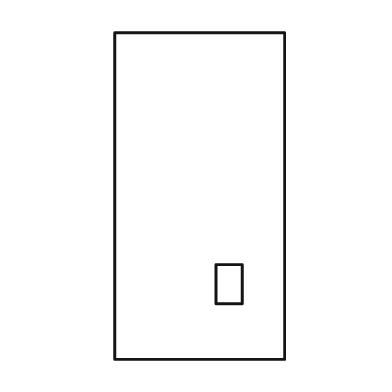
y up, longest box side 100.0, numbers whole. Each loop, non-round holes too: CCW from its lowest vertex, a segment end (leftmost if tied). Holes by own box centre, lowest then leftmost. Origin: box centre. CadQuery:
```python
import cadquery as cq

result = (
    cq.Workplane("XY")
    .moveTo(-26.0, -50.0)
    .lineTo(26.0, -50.0)
    .lineTo(26.0, 50.0)
    .lineTo(-26.0, 50.0)
    .close()
    .moveTo(5.0, -33.0)
    .lineTo(13.0, -33.0)
    .lineTo(13.0, -21.0)
    .lineTo(5.0, -21.0)
    .close()
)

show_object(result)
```